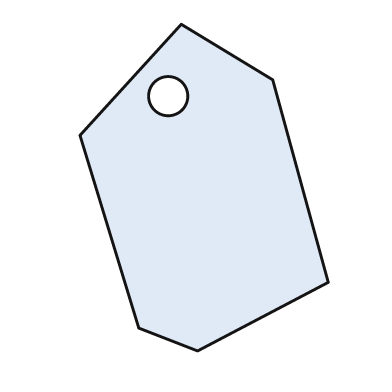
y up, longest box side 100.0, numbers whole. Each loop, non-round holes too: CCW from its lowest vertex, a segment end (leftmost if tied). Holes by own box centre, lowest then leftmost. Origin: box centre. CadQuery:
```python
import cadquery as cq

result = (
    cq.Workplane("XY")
    .moveTo(-2.0, -50.0)
    .lineTo(38.0, -29.0)
    .lineTo(21.0, 33.0)
    .lineTo(-7.0, 50.0)
    .lineTo(-38.0, 16.0)
    .lineTo(-20.0, -43.0)
    .close()
    .moveTo(-11.0, 28.0)
    .circle(6.0)
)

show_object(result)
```